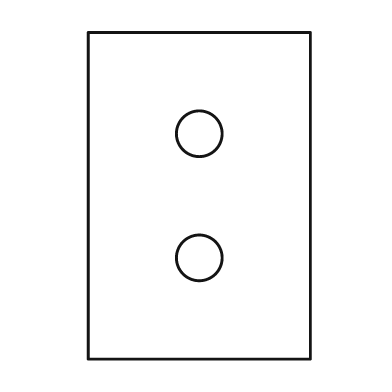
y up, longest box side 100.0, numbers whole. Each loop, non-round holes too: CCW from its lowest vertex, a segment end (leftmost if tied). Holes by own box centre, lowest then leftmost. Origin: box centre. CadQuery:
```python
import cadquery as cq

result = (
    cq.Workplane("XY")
    .moveTo(-34.0, -50.0)
    .lineTo(34.0, -50.0)
    .lineTo(34.0, 50.0)
    .lineTo(-34.0, 50.0)
    .close()
    .moveTo(0.0, -19.0)
    .circle(7.0)
    .moveTo(0.0, 19.0)
    .circle(7.0)
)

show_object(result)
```